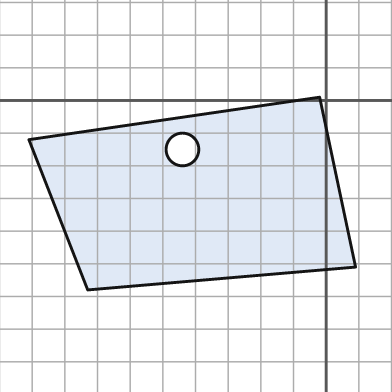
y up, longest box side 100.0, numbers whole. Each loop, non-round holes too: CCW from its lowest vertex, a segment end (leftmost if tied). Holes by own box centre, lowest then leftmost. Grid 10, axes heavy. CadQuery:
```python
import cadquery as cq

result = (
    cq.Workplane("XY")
    .moveTo(-73.0, -58.0)
    .lineTo(9.0, -51.0)
    .lineTo(-2.0, 1.0)
    .lineTo(-91.0, -12.0)
    .close()
    .moveTo(-44.0, -15.0)
    .circle(5.0)
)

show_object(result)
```